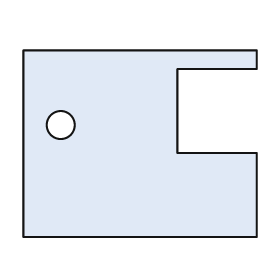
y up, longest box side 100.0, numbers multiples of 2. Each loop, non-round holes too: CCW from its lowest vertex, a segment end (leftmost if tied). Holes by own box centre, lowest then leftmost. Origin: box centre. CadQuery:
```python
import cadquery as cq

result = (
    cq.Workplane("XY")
    .moveTo(-50.0, -40.0)
    .lineTo(50.0, -40.0)
    .lineTo(50.0, -4.0)
    .lineTo(16.0, -4.0)
    .lineTo(16.0, 32.0)
    .lineTo(50.0, 32.0)
    .lineTo(50.0, 40.0)
    .lineTo(-50.0, 40.0)
    .close()
    .moveTo(-34.0, 8.0)
    .circle(6.0)
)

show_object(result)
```